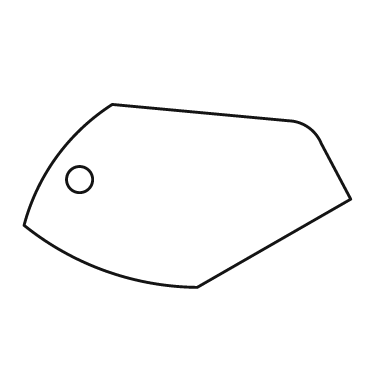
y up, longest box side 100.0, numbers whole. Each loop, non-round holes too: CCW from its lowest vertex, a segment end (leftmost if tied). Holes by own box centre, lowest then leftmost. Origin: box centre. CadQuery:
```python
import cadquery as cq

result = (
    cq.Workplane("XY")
    .moveTo(3.0, -28.0)
    .lineTo(50.0, -1.0)
    .lineTo(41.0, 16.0)
    .threePointArc((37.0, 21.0), (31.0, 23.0))
    .lineTo(-23.0, 28.0)
    .threePointArc((-40.0, 12.0), (-50.0, -9.0))
    .threePointArc((-25.0, -23.0), (3.0, -28.0))
    .close()
    .moveTo(-33.0, 5.0)
    .circle(4.0)
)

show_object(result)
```